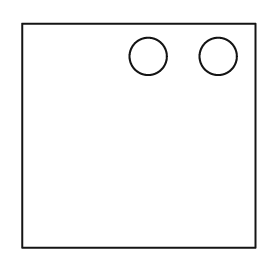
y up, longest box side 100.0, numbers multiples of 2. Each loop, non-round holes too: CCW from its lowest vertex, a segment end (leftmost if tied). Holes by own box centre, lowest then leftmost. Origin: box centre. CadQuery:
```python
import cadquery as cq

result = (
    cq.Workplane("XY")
    .moveTo(-50.0, -48.0)
    .lineTo(50.0, -48.0)
    .lineTo(50.0, 48.0)
    .lineTo(-50.0, 48.0)
    .close()
    .moveTo(4.0, 34.0)
    .circle(8.0)
    .moveTo(34.0, 34.0)
    .circle(8.0)
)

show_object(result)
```